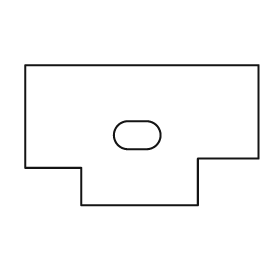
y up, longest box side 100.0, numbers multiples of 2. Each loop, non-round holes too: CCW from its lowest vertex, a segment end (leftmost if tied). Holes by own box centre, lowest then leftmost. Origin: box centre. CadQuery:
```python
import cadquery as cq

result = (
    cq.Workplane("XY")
    .moveTo(-26.0, -30.0)
    .lineTo(24.0, -30.0)
    .lineTo(24.0, -10.0)
    .lineTo(50.0, -10.0)
    .lineTo(50.0, 30.0)
    .lineTo(-50.0, 30.0)
    .lineTo(-50.0, -14.0)
    .lineTo(-26.0, -14.0)
    .close()
    .moveTo(-6.0, -6.0)
    .lineTo(2.0, -6.0)
    .threePointArc((8.0, 0.0), (2.0, 6.0))
    .lineTo(-6.0, 6.0)
    .threePointArc((-12.0, 0.0), (-6.0, -6.0))
    .close()
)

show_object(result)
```